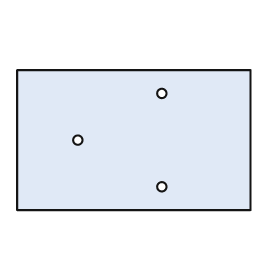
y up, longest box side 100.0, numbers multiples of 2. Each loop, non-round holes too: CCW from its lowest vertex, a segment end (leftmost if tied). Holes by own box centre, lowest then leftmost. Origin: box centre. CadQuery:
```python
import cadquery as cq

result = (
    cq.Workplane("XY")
    .moveTo(-50.0, -30.0)
    .lineTo(50.0, -30.0)
    .lineTo(50.0, 30.0)
    .lineTo(-50.0, 30.0)
    .close()
    .moveTo(12.0, -20.0)
    .circle(2.0)
    .moveTo(-24.0, 0.0)
    .circle(2.0)
    .moveTo(12.0, 20.0)
    .circle(2.0)
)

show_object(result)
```